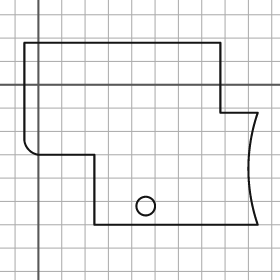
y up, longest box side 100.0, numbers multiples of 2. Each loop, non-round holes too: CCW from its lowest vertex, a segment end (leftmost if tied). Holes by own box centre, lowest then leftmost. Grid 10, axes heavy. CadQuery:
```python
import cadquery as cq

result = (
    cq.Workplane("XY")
    .moveTo(24.0, -60.0)
    .lineTo(94.0, -60.0)
    .threePointArc((90.0, -36.0), (94.0, -12.0))
    .lineTo(78.0, -12.0)
    .lineTo(78.0, 18.0)
    .lineTo(-6.0, 18.0)
    .lineTo(-6.0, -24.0)
    .threePointArc((-4.0, -28.0), (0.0, -30.0))
    .lineTo(24.0, -30.0)
    .close()
    .moveTo(46.0, -52.0)
    .circle(4.0)
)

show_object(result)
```